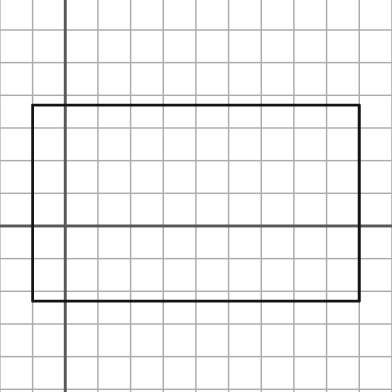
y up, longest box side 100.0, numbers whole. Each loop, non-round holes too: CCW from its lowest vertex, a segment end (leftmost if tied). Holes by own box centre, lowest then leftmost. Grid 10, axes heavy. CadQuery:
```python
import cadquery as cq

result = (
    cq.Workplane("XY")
    .moveTo(-10.0, -23.0)
    .lineTo(90.0, -23.0)
    .lineTo(90.0, 37.0)
    .lineTo(-10.0, 37.0)
    .close()
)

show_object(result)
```